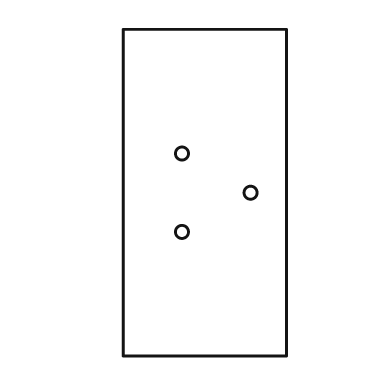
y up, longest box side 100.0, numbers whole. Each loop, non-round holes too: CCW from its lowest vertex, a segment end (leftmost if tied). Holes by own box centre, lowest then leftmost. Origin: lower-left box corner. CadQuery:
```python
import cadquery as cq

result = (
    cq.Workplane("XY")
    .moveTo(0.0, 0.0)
    .lineTo(50.0, 0.0)
    .lineTo(50.0, 100.0)
    .lineTo(0.0, 100.0)
    .close()
    .moveTo(18.0, 38.0)
    .circle(2.0)
    .moveTo(39.0, 50.0)
    .circle(2.0)
    .moveTo(18.0, 62.0)
    .circle(2.0)
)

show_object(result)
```